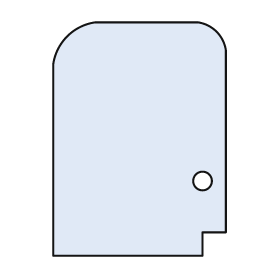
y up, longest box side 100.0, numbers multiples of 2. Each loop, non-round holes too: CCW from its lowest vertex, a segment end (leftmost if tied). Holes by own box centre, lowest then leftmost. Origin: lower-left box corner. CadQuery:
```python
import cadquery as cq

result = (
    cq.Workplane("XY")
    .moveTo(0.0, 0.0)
    .lineTo(64.0, 0.0)
    .lineTo(64.0, 10.0)
    .lineTo(74.0, 10.0)
    .lineTo(74.0, 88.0)
    .threePointArc((70.0, 96.0), (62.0, 100.0))
    .lineTo(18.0, 100.0)
    .threePointArc((6.0, 94.0), (0.0, 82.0))
    .close()
    .moveTo(64.0, 32.0)
    .circle(4.0)
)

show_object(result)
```